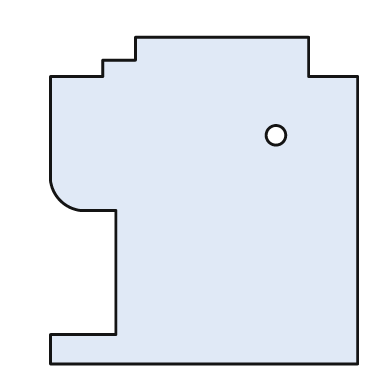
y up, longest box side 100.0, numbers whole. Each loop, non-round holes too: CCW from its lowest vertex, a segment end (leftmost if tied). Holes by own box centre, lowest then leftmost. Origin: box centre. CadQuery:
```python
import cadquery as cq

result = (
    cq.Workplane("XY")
    .moveTo(-47.0, -50.0)
    .lineTo(47.0, -50.0)
    .lineTo(47.0, 38.0)
    .lineTo(32.0, 38.0)
    .lineTo(32.0, 50.0)
    .lineTo(-21.0, 50.0)
    .lineTo(-21.0, 43.0)
    .lineTo(-31.0, 43.0)
    .lineTo(-31.0, 38.0)
    .lineTo(-47.0, 38.0)
    .lineTo(-47.0, 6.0)
    .threePointArc((-44.0, 0.0), (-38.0, -3.0))
    .lineTo(-27.0, -3.0)
    .lineTo(-27.0, -41.0)
    .lineTo(-47.0, -41.0)
    .close()
    .moveTo(22.0, 20.0)
    .circle(3.0)
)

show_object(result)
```